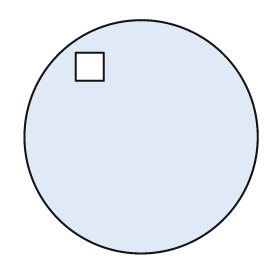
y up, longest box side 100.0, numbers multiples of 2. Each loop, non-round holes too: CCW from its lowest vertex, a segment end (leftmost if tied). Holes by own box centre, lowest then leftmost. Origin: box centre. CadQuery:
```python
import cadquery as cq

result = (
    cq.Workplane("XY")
    .moveTo(0.0, 0.0)
    .circle(50.0)
    .moveTo(-28.0, 24.0)
    .lineTo(-16.0, 24.0)
    .lineTo(-16.0, 36.0)
    .lineTo(-28.0, 36.0)
    .close()
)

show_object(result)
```